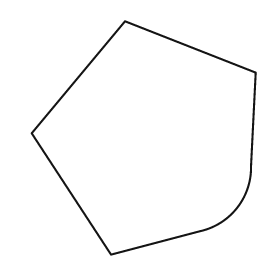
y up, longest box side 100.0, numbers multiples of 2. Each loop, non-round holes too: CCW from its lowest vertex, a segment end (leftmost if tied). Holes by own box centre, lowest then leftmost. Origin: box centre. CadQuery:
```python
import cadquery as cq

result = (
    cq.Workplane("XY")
    .moveTo(-14.0, -50.0)
    .lineTo(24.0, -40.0)
    .threePointArc((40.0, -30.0), (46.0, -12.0))
    .lineTo(48.0, 28.0)
    .lineTo(-8.0, 50.0)
    .lineTo(-48.0, 2.0)
    .close()
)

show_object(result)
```